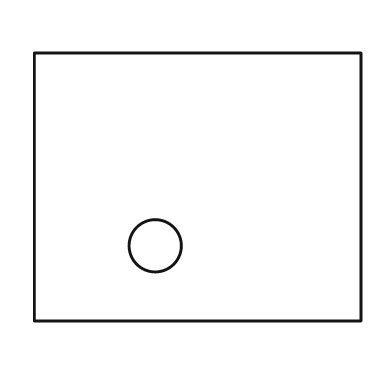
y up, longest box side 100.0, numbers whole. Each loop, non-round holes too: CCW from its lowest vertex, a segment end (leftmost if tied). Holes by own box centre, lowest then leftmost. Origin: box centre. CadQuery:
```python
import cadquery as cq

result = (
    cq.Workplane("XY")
    .moveTo(-50.0, -41.0)
    .lineTo(50.0, -41.0)
    .lineTo(50.0, 41.0)
    .lineTo(-50.0, 41.0)
    .close()
    .moveTo(-13.0, -18.0)
    .circle(8.0)
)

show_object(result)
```